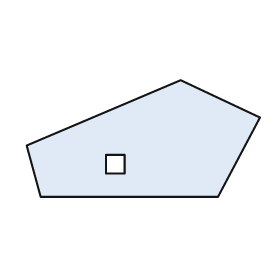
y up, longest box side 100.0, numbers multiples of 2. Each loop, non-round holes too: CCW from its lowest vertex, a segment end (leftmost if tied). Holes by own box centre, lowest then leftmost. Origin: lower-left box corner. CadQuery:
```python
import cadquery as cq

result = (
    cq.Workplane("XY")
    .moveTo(6.0, 0.0)
    .lineTo(82.0, 0.0)
    .lineTo(100.0, 34.0)
    .lineTo(66.0, 50.0)
    .lineTo(0.0, 22.0)
    .close()
    .moveTo(34.0, 10.0)
    .lineTo(42.0, 10.0)
    .lineTo(42.0, 18.0)
    .lineTo(34.0, 18.0)
    .close()
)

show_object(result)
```